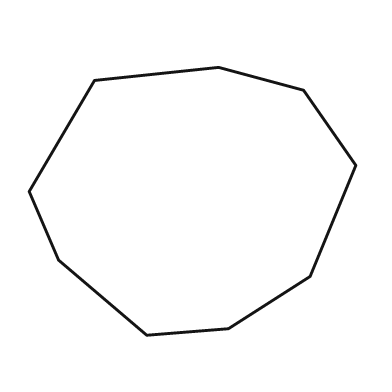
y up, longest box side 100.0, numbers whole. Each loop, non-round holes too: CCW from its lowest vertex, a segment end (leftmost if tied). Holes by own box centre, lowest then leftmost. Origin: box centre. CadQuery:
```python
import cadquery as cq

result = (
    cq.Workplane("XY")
    .moveTo(-14.0, -41.0)
    .lineTo(11.0, -39.0)
    .lineTo(36.0, -23.0)
    .lineTo(50.0, 11.0)
    .lineTo(34.0, 34.0)
    .lineTo(8.0, 41.0)
    .lineTo(-30.0, 37.0)
    .lineTo(-50.0, 3.0)
    .lineTo(-41.0, -18.0)
    .close()
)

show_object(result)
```